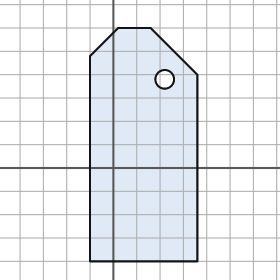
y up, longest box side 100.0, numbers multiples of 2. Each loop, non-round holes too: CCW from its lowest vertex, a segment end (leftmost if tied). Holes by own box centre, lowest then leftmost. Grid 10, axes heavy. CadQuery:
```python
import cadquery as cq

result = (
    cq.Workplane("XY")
    .moveTo(-10.0, -40.0)
    .lineTo(36.0, -40.0)
    .lineTo(36.0, 40.0)
    .lineTo(16.0, 60.0)
    .lineTo(2.0, 60.0)
    .lineTo(-10.0, 48.0)
    .close()
    .moveTo(22.0, 38.0)
    .circle(4.0)
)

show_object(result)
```